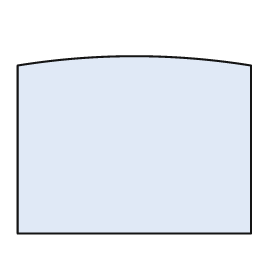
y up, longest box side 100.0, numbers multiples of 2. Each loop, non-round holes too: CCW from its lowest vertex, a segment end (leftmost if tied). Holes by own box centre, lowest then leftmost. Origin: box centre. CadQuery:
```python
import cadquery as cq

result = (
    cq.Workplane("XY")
    .moveTo(-50.0, -38.0)
    .lineTo(50.0, -38.0)
    .lineTo(50.0, 34.0)
    .threePointArc((0.0, 38.0), (-50.0, 34.0))
    .close()
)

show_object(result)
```